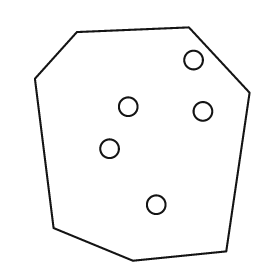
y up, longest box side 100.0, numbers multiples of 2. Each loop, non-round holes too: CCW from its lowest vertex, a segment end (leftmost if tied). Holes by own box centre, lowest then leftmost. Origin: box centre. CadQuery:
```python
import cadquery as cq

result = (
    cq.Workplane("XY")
    .moveTo(-4.0, -50.0)
    .lineTo(36.0, -46.0)
    .lineTo(46.0, 22.0)
    .lineTo(20.0, 50.0)
    .lineTo(-28.0, 48.0)
    .lineTo(-46.0, 28.0)
    .lineTo(-38.0, -36.0)
    .close()
    .moveTo(6.0, -26.0)
    .circle(4.0)
    .moveTo(-14.0, -2.0)
    .circle(4.0)
    .moveTo(26.0, 14.0)
    .circle(4.0)
    .moveTo(-6.0, 16.0)
    .circle(4.0)
    .moveTo(22.0, 36.0)
    .circle(4.0)
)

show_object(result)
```